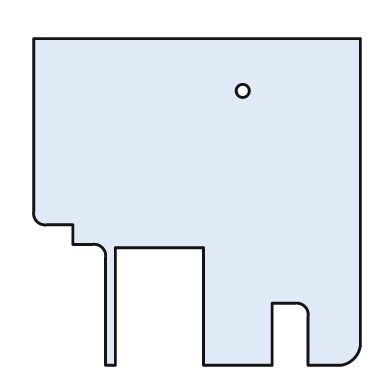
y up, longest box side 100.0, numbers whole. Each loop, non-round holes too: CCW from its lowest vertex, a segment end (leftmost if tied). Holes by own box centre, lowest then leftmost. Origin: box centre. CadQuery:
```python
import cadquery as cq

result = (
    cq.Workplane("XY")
    .moveTo(-28.0, -50.0)
    .lineTo(-25.0, -50.0)
    .lineTo(-25.0, -14.0)
    .lineTo(2.0, -14.0)
    .lineTo(2.0, -50.0)
    .lineTo(23.0, -50.0)
    .lineTo(23.0, -31.0)
    .lineTo(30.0, -31.0)
    .threePointArc((33.0, -32.0), (34.0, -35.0))
    .lineTo(34.0, -50.0)
    .lineTo(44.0, -50.0)
    .threePointArc((48.0, -48.0), (50.0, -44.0))
    .lineTo(50.0, 50.0)
    .lineTo(-50.0, 50.0)
    .lineTo(-50.0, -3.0)
    .threePointArc((-49.0, -6.0), (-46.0, -7.0))
    .lineTo(-38.0, -7.0)
    .lineTo(-38.0, -13.0)
    .lineTo(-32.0, -13.0)
    .threePointArc((-29.0, -14.0), (-28.0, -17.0))
    .close()
    .moveTo(14.0, 34.0)
    .circle(2.0)
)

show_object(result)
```